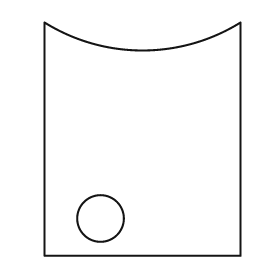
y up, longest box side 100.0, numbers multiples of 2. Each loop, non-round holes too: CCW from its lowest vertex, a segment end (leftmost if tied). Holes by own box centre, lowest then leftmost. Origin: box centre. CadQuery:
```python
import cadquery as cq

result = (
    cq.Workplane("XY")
    .moveTo(-42.0, -50.0)
    .lineTo(42.0, -50.0)
    .lineTo(42.0, 50.0)
    .threePointArc((0.0, 38.0), (-42.0, 50.0))
    .close()
    .moveTo(-18.0, -34.0)
    .circle(10.0)
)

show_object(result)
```